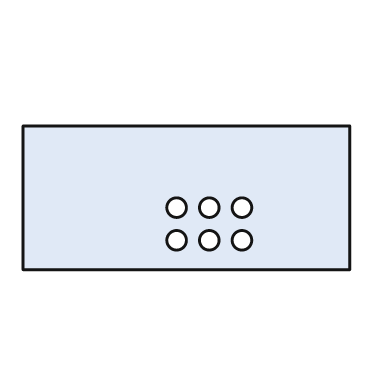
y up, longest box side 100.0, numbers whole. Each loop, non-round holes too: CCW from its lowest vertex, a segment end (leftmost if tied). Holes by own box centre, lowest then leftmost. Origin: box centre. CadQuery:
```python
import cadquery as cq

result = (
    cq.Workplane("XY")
    .moveTo(-50.0, -22.0)
    .lineTo(50.0, -22.0)
    .lineTo(50.0, 22.0)
    .lineTo(-50.0, 22.0)
    .close()
    .moveTo(-3.0, -13.0)
    .circle(3.0)
    .moveTo(7.0, -13.0)
    .circle(3.0)
    .moveTo(17.0, -13.0)
    .circle(3.0)
    .moveTo(-3.0, -3.0)
    .circle(3.0)
    .moveTo(7.0, -3.0)
    .circle(3.0)
    .moveTo(17.0, -3.0)
    .circle(3.0)
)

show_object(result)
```